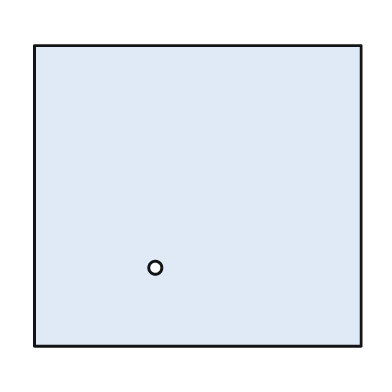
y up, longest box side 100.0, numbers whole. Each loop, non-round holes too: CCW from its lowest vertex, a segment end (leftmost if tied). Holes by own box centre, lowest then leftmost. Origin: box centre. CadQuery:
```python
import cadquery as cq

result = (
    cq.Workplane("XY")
    .moveTo(-50.0, -46.0)
    .lineTo(50.0, -46.0)
    .lineTo(50.0, 46.0)
    .lineTo(-50.0, 46.0)
    .close()
    .moveTo(-13.0, -22.0)
    .circle(2.0)
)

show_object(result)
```